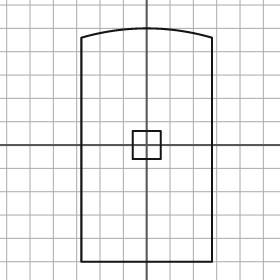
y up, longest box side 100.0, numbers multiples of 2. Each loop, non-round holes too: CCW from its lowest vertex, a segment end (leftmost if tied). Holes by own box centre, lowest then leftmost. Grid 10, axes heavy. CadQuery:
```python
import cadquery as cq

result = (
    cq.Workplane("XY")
    .moveTo(-28.0, -50.0)
    .lineTo(28.0, -50.0)
    .lineTo(28.0, 46.0)
    .threePointArc((0.0, 50.0), (-28.0, 46.0))
    .close()
    .moveTo(-6.0, -6.0)
    .lineTo(6.0, -6.0)
    .lineTo(6.0, 6.0)
    .lineTo(-6.0, 6.0)
    .close()
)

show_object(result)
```